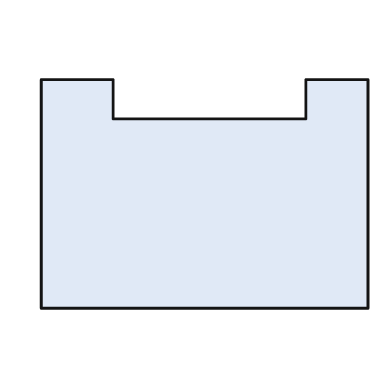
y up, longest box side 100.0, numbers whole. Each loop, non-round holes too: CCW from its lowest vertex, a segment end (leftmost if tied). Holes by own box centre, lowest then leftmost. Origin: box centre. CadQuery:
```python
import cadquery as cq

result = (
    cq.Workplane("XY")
    .moveTo(-50.0, -35.0)
    .lineTo(50.0, -35.0)
    .lineTo(50.0, 35.0)
    .lineTo(31.0, 35.0)
    .lineTo(31.0, 23.0)
    .lineTo(-28.0, 23.0)
    .lineTo(-28.0, 35.0)
    .lineTo(-50.0, 35.0)
    .close()
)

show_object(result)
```